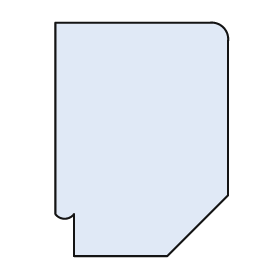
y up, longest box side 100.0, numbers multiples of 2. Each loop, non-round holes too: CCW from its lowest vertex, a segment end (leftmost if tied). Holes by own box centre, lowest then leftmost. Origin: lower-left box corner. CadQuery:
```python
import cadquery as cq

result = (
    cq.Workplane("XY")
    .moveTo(8.0, 0.0)
    .lineTo(48.0, 0.0)
    .lineTo(74.0, 26.0)
    .lineTo(74.0, 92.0)
    .threePointArc((72.0, 98.0), (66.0, 100.0))
    .lineTo(0.0, 100.0)
    .lineTo(0.0, 18.0)
    .threePointArc((4.0, 16.0), (8.0, 18.0))
    .close()
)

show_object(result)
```